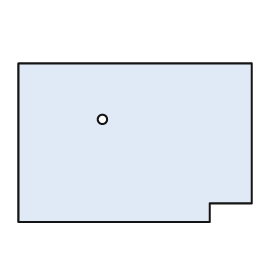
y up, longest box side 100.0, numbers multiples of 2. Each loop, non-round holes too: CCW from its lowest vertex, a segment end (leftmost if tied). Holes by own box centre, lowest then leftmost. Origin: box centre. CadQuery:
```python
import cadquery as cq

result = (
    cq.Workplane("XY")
    .moveTo(-50.0, -34.0)
    .lineTo(32.0, -34.0)
    .lineTo(32.0, -26.0)
    .lineTo(50.0, -26.0)
    .lineTo(50.0, 34.0)
    .lineTo(-50.0, 34.0)
    .close()
    .moveTo(-14.0, 10.0)
    .circle(2.0)
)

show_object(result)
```